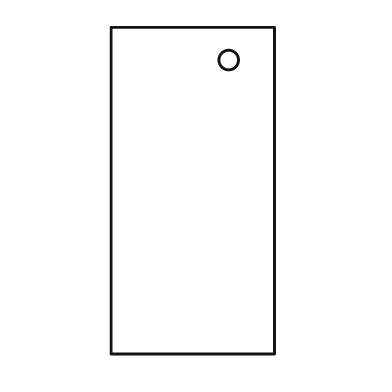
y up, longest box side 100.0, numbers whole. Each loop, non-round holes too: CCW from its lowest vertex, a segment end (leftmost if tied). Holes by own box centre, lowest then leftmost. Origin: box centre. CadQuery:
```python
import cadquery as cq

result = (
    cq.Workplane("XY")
    .moveTo(-25.0, -50.0)
    .lineTo(25.0, -50.0)
    .lineTo(25.0, 50.0)
    .lineTo(-25.0, 50.0)
    .close()
    .moveTo(11.0, 40.0)
    .circle(3.0)
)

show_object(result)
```